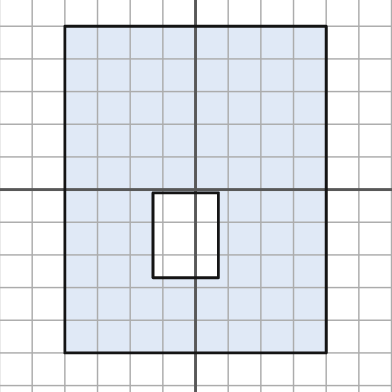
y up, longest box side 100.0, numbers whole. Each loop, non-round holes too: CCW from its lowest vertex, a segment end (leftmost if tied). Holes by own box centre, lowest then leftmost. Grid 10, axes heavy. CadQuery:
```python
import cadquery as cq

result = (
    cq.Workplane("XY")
    .moveTo(-40.0, -50.0)
    .lineTo(40.0, -50.0)
    .lineTo(40.0, 50.0)
    .lineTo(-40.0, 50.0)
    .close()
    .moveTo(-13.0, -27.0)
    .lineTo(7.0, -27.0)
    .lineTo(7.0, -1.0)
    .lineTo(-13.0, -1.0)
    .close()
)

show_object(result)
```